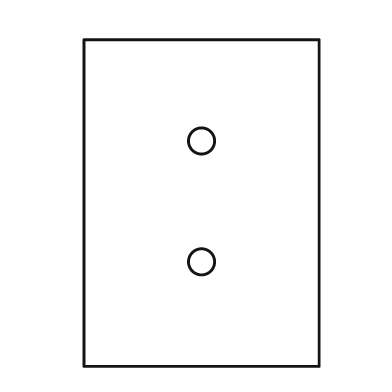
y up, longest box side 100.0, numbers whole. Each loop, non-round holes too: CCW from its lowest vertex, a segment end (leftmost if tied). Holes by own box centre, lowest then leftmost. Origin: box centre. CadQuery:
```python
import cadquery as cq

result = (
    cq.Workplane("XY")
    .moveTo(-36.0, -50.0)
    .lineTo(36.0, -50.0)
    .lineTo(36.0, 50.0)
    .lineTo(-36.0, 50.0)
    .close()
    .moveTo(0.0, -18.0)
    .circle(4.0)
    .moveTo(0.0, 19.0)
    .circle(4.0)
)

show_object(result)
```